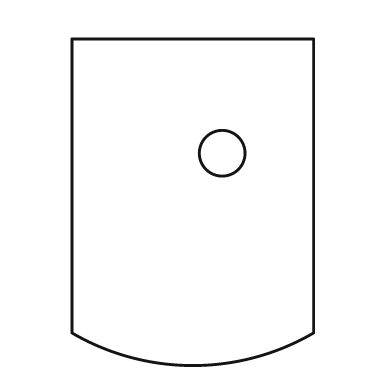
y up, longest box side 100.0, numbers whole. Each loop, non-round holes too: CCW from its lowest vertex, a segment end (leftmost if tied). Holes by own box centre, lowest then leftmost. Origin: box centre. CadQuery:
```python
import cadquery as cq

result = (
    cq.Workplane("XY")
    .moveTo(-37.0, -40.0)
    .threePointArc((0.0, -50.0), (37.0, -40.0))
    .lineTo(37.0, 50.0)
    .lineTo(-37.0, 50.0)
    .close()
    .moveTo(9.0, 15.0)
    .circle(7.0)
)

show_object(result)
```